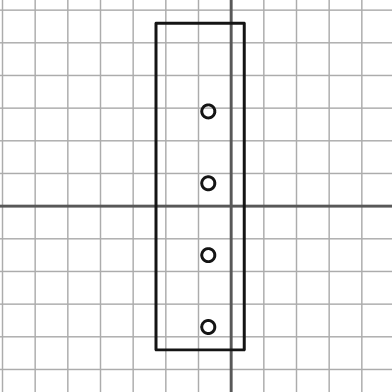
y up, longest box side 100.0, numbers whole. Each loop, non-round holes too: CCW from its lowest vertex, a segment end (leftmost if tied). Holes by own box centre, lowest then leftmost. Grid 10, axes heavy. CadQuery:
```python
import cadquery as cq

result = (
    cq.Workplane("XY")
    .moveTo(-23.0, -44.0)
    .lineTo(4.0, -44.0)
    .lineTo(4.0, 56.0)
    .lineTo(-23.0, 56.0)
    .close()
    .moveTo(-7.0, -37.0)
    .circle(2.0)
    .moveTo(-7.0, -15.0)
    .circle(2.0)
    .moveTo(-7.0, 7.0)
    .circle(2.0)
    .moveTo(-7.0, 29.0)
    .circle(2.0)
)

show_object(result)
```